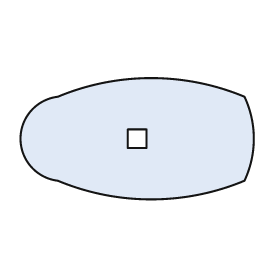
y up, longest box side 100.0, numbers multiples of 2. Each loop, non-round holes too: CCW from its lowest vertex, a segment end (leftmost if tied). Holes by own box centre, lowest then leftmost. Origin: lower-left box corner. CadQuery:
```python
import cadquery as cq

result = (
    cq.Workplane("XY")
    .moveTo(16.0, 8.0)
    .threePointArc((56.0, 0.0), (96.0, 8.0))
    .threePointArc((100.0, 26.0), (96.0, 44.0))
    .threePointArc((56.0, 52.0), (16.0, 44.0))
    .threePointArc((0.0, 26.0), (16.0, 8.0))
    .close()
    .moveTo(46.0, 22.0)
    .lineTo(54.0, 22.0)
    .lineTo(54.0, 30.0)
    .lineTo(46.0, 30.0)
    .close()
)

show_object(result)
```